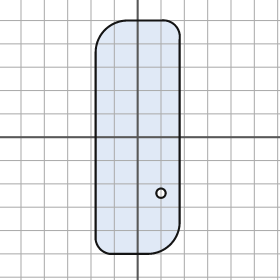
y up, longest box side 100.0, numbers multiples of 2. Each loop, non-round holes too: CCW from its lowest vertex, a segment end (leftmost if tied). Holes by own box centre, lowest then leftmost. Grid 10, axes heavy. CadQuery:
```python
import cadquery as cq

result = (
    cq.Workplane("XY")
    .moveTo(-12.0, -50.0)
    .lineTo(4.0, -50.0)
    .threePointArc((14.0, -46.0), (18.0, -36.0))
    .lineTo(18.0, 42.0)
    .threePointArc((16.0, 48.0), (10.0, 50.0))
    .lineTo(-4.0, 50.0)
    .threePointArc((-14.0, 46.0), (-18.0, 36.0))
    .lineTo(-18.0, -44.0)
    .threePointArc((-16.0, -48.0), (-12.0, -50.0))
    .close()
    .moveTo(10.0, -24.0)
    .circle(2.0)
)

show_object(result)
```